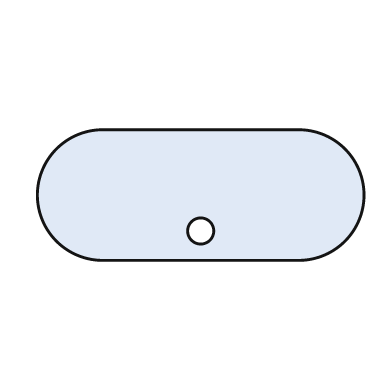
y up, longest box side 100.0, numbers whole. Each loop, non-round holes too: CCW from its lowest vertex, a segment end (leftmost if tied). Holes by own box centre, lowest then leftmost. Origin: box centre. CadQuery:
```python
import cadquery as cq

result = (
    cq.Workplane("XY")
    .moveTo(-30.0, -20.0)
    .lineTo(30.0, -20.0)
    .threePointArc((50.0, 0.0), (30.0, 20.0))
    .lineTo(-30.0, 20.0)
    .threePointArc((-50.0, 0.0), (-30.0, -20.0))
    .close()
    .moveTo(0.0, -11.0)
    .circle(4.0)
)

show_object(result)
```